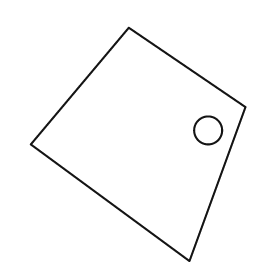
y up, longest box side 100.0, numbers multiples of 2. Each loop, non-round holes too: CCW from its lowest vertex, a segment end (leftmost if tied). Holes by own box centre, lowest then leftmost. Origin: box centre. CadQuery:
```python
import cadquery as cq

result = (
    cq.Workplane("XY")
    .moveTo(22.0, -50.0)
    .lineTo(46.0, 16.0)
    .lineTo(-4.0, 50.0)
    .lineTo(-46.0, 0.0)
    .close()
    .moveTo(30.0, 6.0)
    .circle(6.0)
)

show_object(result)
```